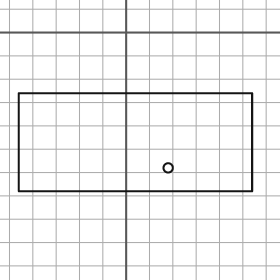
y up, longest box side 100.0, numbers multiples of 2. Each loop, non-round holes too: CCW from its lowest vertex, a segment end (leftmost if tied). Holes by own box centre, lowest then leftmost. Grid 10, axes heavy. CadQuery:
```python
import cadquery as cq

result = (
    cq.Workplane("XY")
    .moveTo(-46.0, -68.0)
    .lineTo(54.0, -68.0)
    .lineTo(54.0, -26.0)
    .lineTo(-46.0, -26.0)
    .close()
    .moveTo(18.0, -58.0)
    .circle(2.0)
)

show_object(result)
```